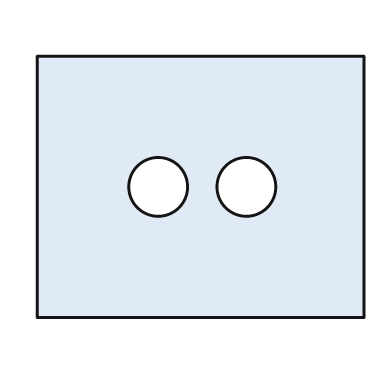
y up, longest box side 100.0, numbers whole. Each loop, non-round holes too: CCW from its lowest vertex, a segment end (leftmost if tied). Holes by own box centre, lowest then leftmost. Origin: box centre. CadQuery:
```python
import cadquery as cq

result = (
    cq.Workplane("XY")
    .moveTo(-50.0, -40.0)
    .lineTo(50.0, -40.0)
    .lineTo(50.0, 40.0)
    .lineTo(-50.0, 40.0)
    .close()
    .moveTo(-13.0, 0.0)
    .circle(9.0)
    .moveTo(14.0, 0.0)
    .circle(9.0)
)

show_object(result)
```